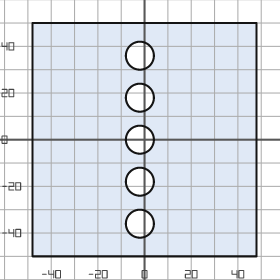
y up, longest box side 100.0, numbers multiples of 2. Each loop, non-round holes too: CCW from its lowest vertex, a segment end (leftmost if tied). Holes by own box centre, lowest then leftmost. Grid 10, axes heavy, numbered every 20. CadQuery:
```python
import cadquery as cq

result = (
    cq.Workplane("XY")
    .moveTo(-48.0, -50.0)
    .lineTo(48.0, -50.0)
    .lineTo(48.0, 50.0)
    .lineTo(-48.0, 50.0)
    .close()
    .moveTo(-2.0, -36.0)
    .circle(6.0)
    .moveTo(-2.0, -18.0)
    .circle(6.0)
    .moveTo(-2.0, 0.0)
    .circle(6.0)
    .moveTo(-2.0, 18.0)
    .circle(6.0)
    .moveTo(-2.0, 36.0)
    .circle(6.0)
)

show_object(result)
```